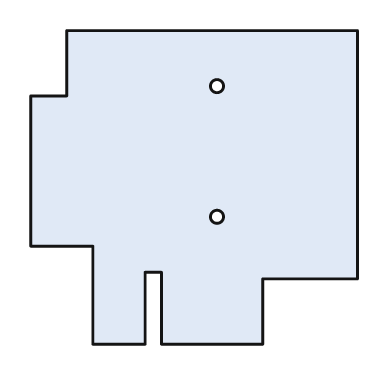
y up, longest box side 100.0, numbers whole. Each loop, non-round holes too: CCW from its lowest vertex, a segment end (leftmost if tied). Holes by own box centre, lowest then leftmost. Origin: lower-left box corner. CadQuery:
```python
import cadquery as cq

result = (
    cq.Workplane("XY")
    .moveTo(19.0, 0.0)
    .lineTo(35.0, 0.0)
    .lineTo(35.0, 22.0)
    .lineTo(40.0, 22.0)
    .lineTo(40.0, 0.0)
    .lineTo(71.0, 0.0)
    .lineTo(71.0, 20.0)
    .lineTo(100.0, 20.0)
    .lineTo(100.0, 96.0)
    .lineTo(11.0, 96.0)
    .lineTo(11.0, 76.0)
    .lineTo(0.0, 76.0)
    .lineTo(0.0, 30.0)
    .lineTo(19.0, 30.0)
    .close()
    .moveTo(57.0, 39.0)
    .circle(2.0)
    .moveTo(57.0, 79.0)
    .circle(2.0)
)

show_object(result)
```